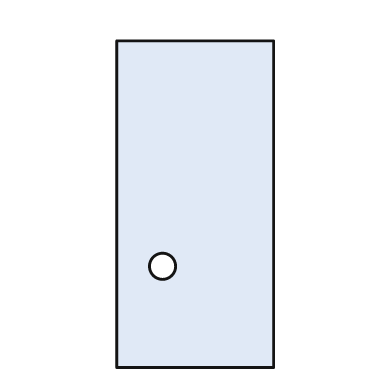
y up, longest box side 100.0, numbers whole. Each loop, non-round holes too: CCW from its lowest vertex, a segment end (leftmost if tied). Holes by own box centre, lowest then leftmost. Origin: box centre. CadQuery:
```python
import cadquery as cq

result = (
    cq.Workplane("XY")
    .moveTo(-24.0, -50.0)
    .lineTo(24.0, -50.0)
    .lineTo(24.0, 50.0)
    .lineTo(-24.0, 50.0)
    .close()
    .moveTo(-10.0, -19.0)
    .circle(4.0)
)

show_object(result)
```